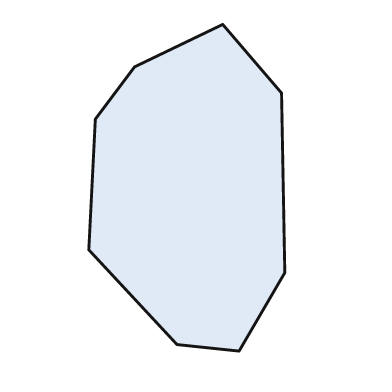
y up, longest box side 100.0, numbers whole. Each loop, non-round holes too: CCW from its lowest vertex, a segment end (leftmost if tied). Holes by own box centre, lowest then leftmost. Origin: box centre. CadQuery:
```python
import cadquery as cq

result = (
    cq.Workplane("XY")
    .moveTo(16.0, -50.0)
    .lineTo(30.0, -26.0)
    .lineTo(29.0, 29.0)
    .lineTo(11.0, 50.0)
    .lineTo(-16.0, 37.0)
    .lineTo(-28.0, 21.0)
    .lineTo(-30.0, -19.0)
    .lineTo(-3.0, -48.0)
    .close()
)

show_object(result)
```